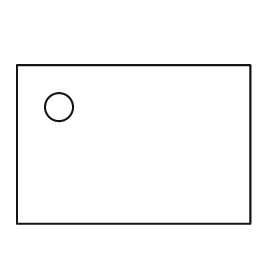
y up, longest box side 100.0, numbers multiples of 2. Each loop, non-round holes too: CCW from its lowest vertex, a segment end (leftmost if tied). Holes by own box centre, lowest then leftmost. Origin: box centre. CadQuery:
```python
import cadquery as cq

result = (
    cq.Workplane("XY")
    .moveTo(-50.0, -34.0)
    .lineTo(50.0, -34.0)
    .lineTo(50.0, 34.0)
    .lineTo(-50.0, 34.0)
    .close()
    .moveTo(-32.0, 16.0)
    .circle(6.0)
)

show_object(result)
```